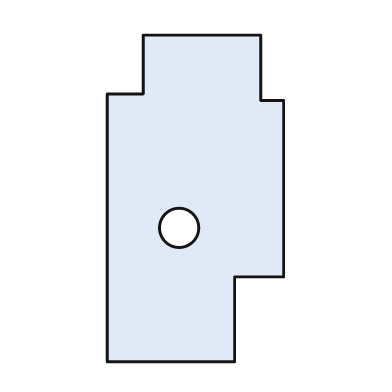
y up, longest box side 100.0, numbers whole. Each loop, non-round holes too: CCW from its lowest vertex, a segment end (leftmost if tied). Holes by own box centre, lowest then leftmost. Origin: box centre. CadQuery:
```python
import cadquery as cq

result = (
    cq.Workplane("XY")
    .moveTo(-27.0, -50.0)
    .lineTo(12.0, -50.0)
    .lineTo(12.0, -24.0)
    .lineTo(27.0, -24.0)
    .lineTo(27.0, 30.0)
    .lineTo(20.0, 30.0)
    .lineTo(20.0, 50.0)
    .lineTo(-16.0, 50.0)
    .lineTo(-16.0, 32.0)
    .lineTo(-27.0, 32.0)
    .close()
    .moveTo(-5.0, -9.0)
    .circle(6.0)
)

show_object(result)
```